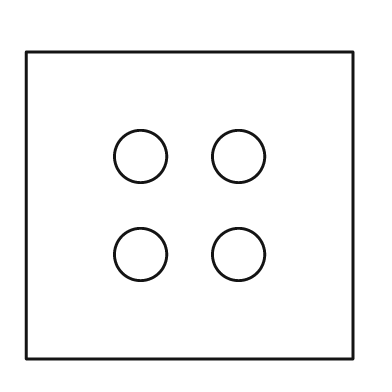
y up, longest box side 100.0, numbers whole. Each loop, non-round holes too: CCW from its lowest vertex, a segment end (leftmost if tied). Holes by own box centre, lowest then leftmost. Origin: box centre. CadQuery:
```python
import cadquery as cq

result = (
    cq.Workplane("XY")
    .moveTo(-50.0, -47.0)
    .lineTo(50.0, -47.0)
    .lineTo(50.0, 47.0)
    .lineTo(-50.0, 47.0)
    .close()
    .moveTo(-15.0, -15.0)
    .circle(8.0)
    .moveTo(15.0, -15.0)
    .circle(8.0)
    .moveTo(-15.0, 15.0)
    .circle(8.0)
    .moveTo(15.0, 15.0)
    .circle(8.0)
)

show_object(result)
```